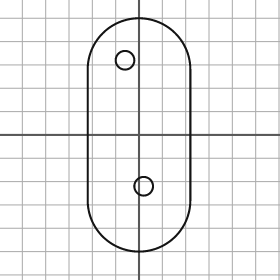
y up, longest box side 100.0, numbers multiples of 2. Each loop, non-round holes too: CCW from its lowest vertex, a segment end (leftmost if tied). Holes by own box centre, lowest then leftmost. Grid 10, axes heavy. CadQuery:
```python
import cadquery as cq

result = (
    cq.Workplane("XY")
    .moveTo(-22.0, -28.0)
    .threePointArc((0.0, -50.0), (22.0, -28.0))
    .lineTo(22.0, 28.0)
    .threePointArc((0.0, 50.0), (-22.0, 28.0))
    .close()
    .moveTo(2.0, -22.0)
    .circle(4.0)
    .moveTo(-6.0, 32.0)
    .circle(4.0)
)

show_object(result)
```